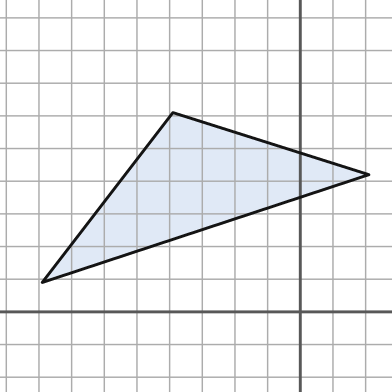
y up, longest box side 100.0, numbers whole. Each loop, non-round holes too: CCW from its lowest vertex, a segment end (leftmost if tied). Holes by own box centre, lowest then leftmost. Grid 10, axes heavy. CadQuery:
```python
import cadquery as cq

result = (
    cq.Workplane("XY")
    .moveTo(-79.0, 9.0)
    .lineTo(21.0, 42.0)
    .lineTo(-39.0, 61.0)
    .close()
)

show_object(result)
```